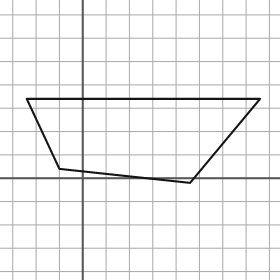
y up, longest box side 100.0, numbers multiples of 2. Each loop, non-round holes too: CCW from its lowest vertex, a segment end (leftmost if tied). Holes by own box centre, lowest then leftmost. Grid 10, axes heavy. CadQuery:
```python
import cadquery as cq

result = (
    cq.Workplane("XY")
    .moveTo(46.0, -2.0)
    .lineTo(76.0, 34.0)
    .lineTo(-24.0, 34.0)
    .lineTo(-10.0, 4.0)
    .close()
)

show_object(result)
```